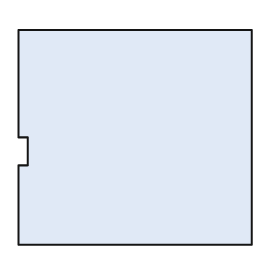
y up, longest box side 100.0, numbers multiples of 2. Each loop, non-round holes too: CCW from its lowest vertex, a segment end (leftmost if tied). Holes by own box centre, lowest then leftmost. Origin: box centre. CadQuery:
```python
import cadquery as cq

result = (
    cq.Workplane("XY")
    .moveTo(-50.0, -46.0)
    .lineTo(50.0, -46.0)
    .lineTo(50.0, 46.0)
    .lineTo(-50.0, 46.0)
    .lineTo(-50.0, 0.0)
    .lineTo(-46.0, 0.0)
    .lineTo(-46.0, -12.0)
    .lineTo(-50.0, -12.0)
    .close()
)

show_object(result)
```